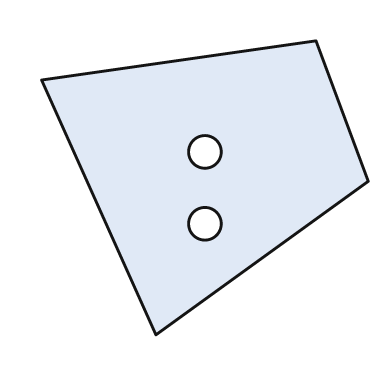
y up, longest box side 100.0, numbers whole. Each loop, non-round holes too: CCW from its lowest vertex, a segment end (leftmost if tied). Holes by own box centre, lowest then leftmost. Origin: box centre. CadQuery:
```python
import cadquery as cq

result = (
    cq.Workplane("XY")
    .moveTo(-15.0, -45.0)
    .lineTo(50.0, 2.0)
    .lineTo(34.0, 45.0)
    .lineTo(-50.0, 33.0)
    .close()
    .moveTo(0.0, -11.0)
    .circle(5.0)
    .moveTo(0.0, 11.0)
    .circle(5.0)
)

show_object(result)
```